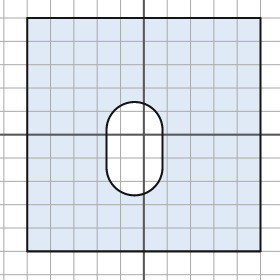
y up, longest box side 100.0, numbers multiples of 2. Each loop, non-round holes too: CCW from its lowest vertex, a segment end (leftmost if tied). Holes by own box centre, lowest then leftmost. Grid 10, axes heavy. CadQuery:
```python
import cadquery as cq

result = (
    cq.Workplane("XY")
    .moveTo(-50.0, -50.0)
    .lineTo(50.0, -50.0)
    .lineTo(50.0, 50.0)
    .lineTo(-50.0, 50.0)
    .close()
    .moveTo(-16.0, -14.0)
    .threePointArc((-4.0, -26.0), (8.0, -14.0))
    .lineTo(8.0, 2.0)
    .threePointArc((-4.0, 14.0), (-16.0, 2.0))
    .close()
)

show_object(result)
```